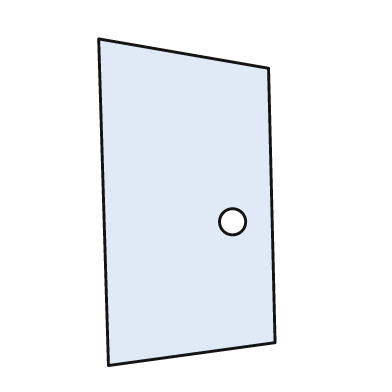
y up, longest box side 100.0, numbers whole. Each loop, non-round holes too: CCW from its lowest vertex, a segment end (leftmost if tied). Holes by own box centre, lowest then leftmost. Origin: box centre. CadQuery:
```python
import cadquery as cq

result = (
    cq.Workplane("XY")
    .moveTo(-24.0, -50.0)
    .lineTo(27.0, -43.0)
    .lineTo(25.0, 41.0)
    .lineTo(-27.0, 50.0)
    .close()
    .moveTo(14.0, -6.0)
    .circle(4.0)
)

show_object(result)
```